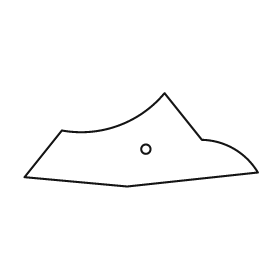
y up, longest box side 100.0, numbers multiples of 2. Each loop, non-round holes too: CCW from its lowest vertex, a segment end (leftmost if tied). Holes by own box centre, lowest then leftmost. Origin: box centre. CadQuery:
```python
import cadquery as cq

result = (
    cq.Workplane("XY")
    .moveTo(-6.0, -20.0)
    .lineTo(50.0, -14.0)
    .threePointArc((40.0, -4.0), (26.0, 0.0))
    .lineTo(10.0, 20.0)
    .threePointArc((-10.0, 6.0), (-34.0, 4.0))
    .lineTo(-50.0, -16.0)
    .close()
    .moveTo(2.0, -4.0)
    .circle(2.0)
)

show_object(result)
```